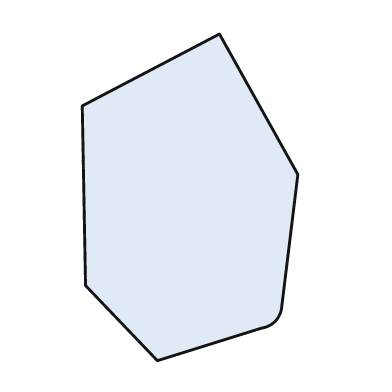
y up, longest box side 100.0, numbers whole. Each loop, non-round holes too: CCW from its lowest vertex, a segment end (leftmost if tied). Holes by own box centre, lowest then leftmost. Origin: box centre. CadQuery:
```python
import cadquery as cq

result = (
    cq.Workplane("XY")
    .moveTo(-10.0, -50.0)
    .lineTo(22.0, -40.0)
    .threePointArc((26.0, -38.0), (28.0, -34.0))
    .lineTo(33.0, 7.0)
    .lineTo(9.0, 50.0)
    .lineTo(-33.0, 28.0)
    .lineTo(-32.0, -27.0)
    .close()
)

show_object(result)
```